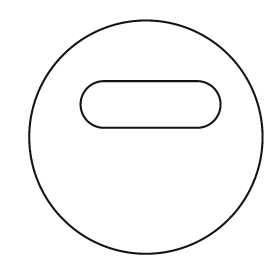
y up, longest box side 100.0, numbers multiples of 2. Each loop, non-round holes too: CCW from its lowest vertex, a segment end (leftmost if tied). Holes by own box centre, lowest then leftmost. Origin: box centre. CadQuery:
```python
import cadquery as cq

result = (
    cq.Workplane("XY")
    .moveTo(0.0, 0.0)
    .circle(50.0)
    .moveTo(-18.0, 4.0)
    .lineTo(22.0, 4.0)
    .threePointArc((32.0, 14.0), (22.0, 24.0))
    .lineTo(-18.0, 24.0)
    .threePointArc((-28.0, 14.0), (-18.0, 4.0))
    .close()
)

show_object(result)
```